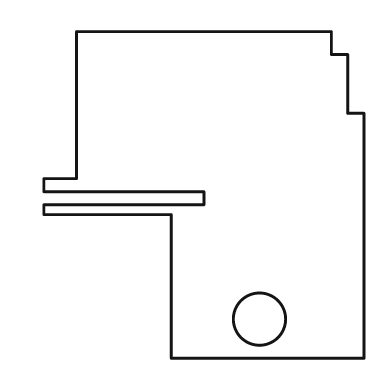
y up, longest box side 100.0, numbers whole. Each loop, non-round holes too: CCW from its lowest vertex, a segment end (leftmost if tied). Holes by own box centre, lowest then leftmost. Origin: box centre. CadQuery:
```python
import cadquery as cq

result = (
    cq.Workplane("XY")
    .moveTo(-10.0, -50.0)
    .lineTo(49.0, -50.0)
    .lineTo(49.0, 25.0)
    .lineTo(44.0, 25.0)
    .lineTo(44.0, 43.0)
    .lineTo(39.0, 43.0)
    .lineTo(39.0, 50.0)
    .lineTo(-39.0, 50.0)
    .lineTo(-39.0, 5.0)
    .lineTo(-49.0, 5.0)
    .lineTo(-49.0, 1.0)
    .lineTo(0.0, 1.0)
    .lineTo(0.0, -3.0)
    .lineTo(-49.0, -3.0)
    .lineTo(-49.0, -6.0)
    .lineTo(-10.0, -6.0)
    .close()
    .moveTo(17.0, -38.0)
    .circle(8.0)
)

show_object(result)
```